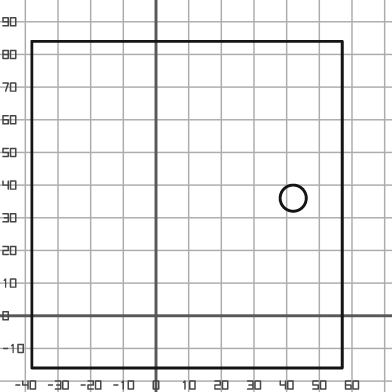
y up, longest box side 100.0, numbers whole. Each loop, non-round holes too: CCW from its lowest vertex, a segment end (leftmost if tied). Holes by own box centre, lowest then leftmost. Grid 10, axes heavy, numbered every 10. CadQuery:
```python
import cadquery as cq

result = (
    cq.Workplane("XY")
    .moveTo(-38.0, -16.0)
    .lineTo(57.0, -16.0)
    .lineTo(57.0, 84.0)
    .lineTo(-38.0, 84.0)
    .close()
    .moveTo(42.0, 36.0)
    .circle(4.0)
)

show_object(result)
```